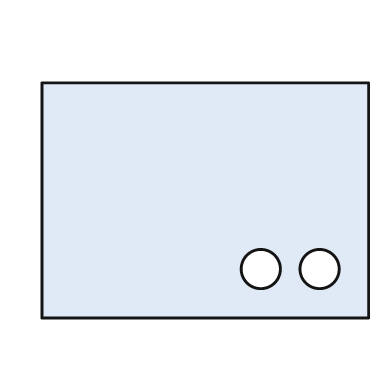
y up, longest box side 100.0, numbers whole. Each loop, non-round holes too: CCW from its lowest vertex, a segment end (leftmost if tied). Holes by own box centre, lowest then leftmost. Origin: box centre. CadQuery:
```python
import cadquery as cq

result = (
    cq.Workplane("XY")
    .moveTo(-50.0, -36.0)
    .lineTo(50.0, -36.0)
    .lineTo(50.0, 36.0)
    .lineTo(-50.0, 36.0)
    .close()
    .moveTo(17.0, -21.0)
    .circle(6.0)
    .moveTo(35.0, -21.0)
    .circle(6.0)
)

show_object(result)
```